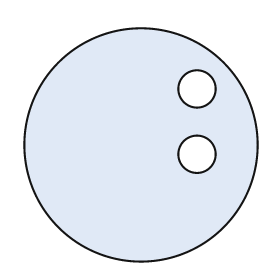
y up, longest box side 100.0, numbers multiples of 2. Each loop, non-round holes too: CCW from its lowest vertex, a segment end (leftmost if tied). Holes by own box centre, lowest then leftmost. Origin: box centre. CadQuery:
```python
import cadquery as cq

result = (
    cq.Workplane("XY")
    .moveTo(0.0, 0.0)
    .circle(50.0)
    .moveTo(24.0, -4.0)
    .circle(8.0)
    .moveTo(24.0, 24.0)
    .circle(8.0)
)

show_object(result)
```